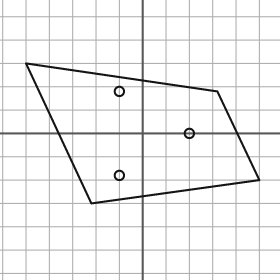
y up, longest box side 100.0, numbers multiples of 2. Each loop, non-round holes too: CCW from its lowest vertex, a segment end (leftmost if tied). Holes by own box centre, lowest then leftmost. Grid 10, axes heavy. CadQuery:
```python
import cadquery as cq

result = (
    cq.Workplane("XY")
    .moveTo(-22.0, -30.0)
    .lineTo(50.0, -20.0)
    .lineTo(32.0, 18.0)
    .lineTo(-50.0, 30.0)
    .close()
    .moveTo(-10.0, -18.0)
    .circle(2.0)
    .moveTo(20.0, 0.0)
    .circle(2.0)
    .moveTo(-10.0, 18.0)
    .circle(2.0)
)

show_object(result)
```